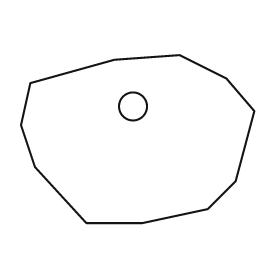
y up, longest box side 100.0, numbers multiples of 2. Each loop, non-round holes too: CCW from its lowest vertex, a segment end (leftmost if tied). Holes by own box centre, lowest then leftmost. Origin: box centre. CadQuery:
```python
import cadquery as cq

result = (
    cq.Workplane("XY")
    .moveTo(-22.0, -36.0)
    .lineTo(2.0, -36.0)
    .lineTo(30.0, -30.0)
    .lineTo(42.0, -18.0)
    .lineTo(50.0, 12.0)
    .lineTo(38.0, 26.0)
    .lineTo(18.0, 36.0)
    .lineTo(-10.0, 34.0)
    .lineTo(-46.0, 24.0)
    .lineTo(-50.0, 6.0)
    .lineTo(-44.0, -12.0)
    .close()
    .moveTo(-2.0, 14.0)
    .circle(6.0)
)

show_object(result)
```